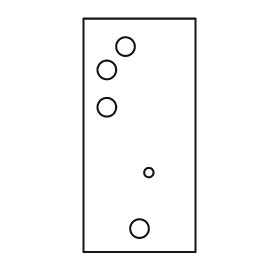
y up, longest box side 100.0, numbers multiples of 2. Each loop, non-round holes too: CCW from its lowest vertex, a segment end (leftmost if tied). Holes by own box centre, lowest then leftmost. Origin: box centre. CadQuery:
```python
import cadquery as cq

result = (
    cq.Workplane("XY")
    .moveTo(-24.0, -50.0)
    .lineTo(24.0, -50.0)
    .lineTo(24.0, 50.0)
    .lineTo(-24.0, 50.0)
    .close()
    .moveTo(0.0, -40.0)
    .circle(4.0)
    .moveTo(4.0, -16.0)
    .circle(2.0)
    .moveTo(-14.0, 12.0)
    .circle(4.0)
    .moveTo(-14.0, 28.0)
    .circle(4.0)
    .moveTo(-6.0, 38.0)
    .circle(4.0)
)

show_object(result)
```